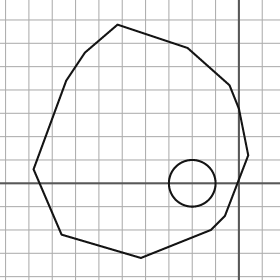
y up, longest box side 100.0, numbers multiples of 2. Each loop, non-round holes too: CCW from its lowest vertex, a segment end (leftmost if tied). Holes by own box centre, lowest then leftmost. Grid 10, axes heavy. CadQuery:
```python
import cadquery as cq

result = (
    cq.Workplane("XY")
    .moveTo(-42.0, -32.0)
    .lineTo(-12.0, -20.0)
    .lineTo(-6.0, -14.0)
    .lineTo(4.0, 12.0)
    .lineTo(0.0, 32.0)
    .lineTo(-4.0, 42.0)
    .lineTo(-22.0, 58.0)
    .lineTo(-52.0, 68.0)
    .lineTo(-66.0, 56.0)
    .lineTo(-74.0, 44.0)
    .lineTo(-88.0, 6.0)
    .lineTo(-76.0, -22.0)
    .close()
    .moveTo(-20.0, 0.0)
    .circle(10.0)
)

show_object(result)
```